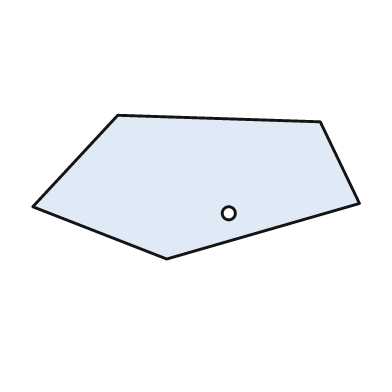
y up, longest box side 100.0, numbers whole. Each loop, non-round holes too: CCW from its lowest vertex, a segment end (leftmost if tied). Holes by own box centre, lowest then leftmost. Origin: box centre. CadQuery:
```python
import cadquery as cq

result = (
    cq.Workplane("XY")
    .moveTo(-9.0, -22.0)
    .lineTo(50.0, -5.0)
    .lineTo(38.0, 20.0)
    .lineTo(-24.0, 22.0)
    .lineTo(-50.0, -6.0)
    .close()
    .moveTo(10.0, -8.0)
    .circle(2.0)
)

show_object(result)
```